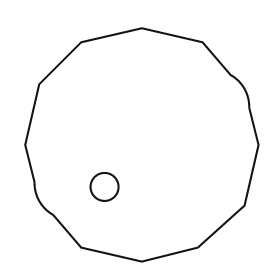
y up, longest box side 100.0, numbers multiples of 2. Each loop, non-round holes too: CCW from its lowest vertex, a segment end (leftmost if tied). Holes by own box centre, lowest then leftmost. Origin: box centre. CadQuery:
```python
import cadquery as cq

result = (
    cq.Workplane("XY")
    .moveTo(0.0, -50.0)
    .lineTo(24.0, -44.0)
    .lineTo(44.0, -26.0)
    .lineTo(50.0, 0.0)
    .lineTo(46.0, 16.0)
    .threePointArc((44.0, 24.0), (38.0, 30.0))
    .lineTo(26.0, 44.0)
    .lineTo(0.0, 50.0)
    .lineTo(-26.0, 44.0)
    .lineTo(-44.0, 26.0)
    .lineTo(-50.0, 0.0)
    .lineTo(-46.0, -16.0)
    .threePointArc((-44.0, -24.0), (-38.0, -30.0))
    .lineTo(-26.0, -44.0)
    .close()
    .moveTo(-16.0, -18.0)
    .circle(6.0)
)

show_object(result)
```